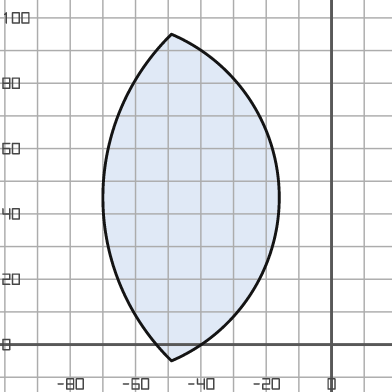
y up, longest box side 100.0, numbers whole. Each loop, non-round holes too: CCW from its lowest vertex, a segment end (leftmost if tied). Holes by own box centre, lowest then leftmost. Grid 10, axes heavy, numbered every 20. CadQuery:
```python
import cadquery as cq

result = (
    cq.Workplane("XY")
    .moveTo(-49.0, -5.0)
    .threePointArc((-16.0, 45.0), (-49.0, 95.0))
    .threePointArc((-70.0, 45.0), (-49.0, -5.0))
    .close()
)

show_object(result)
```